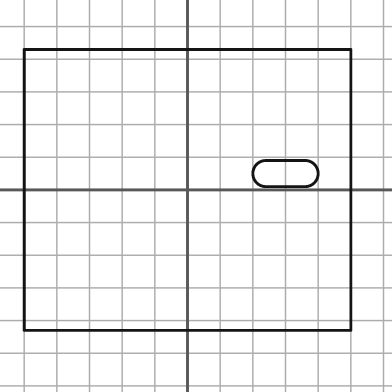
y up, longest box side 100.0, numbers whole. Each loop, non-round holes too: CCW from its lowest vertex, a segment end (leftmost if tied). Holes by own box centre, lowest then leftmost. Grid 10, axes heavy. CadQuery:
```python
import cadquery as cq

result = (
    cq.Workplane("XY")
    .moveTo(-50.0, -43.0)
    .lineTo(50.0, -43.0)
    .lineTo(50.0, 43.0)
    .lineTo(-50.0, 43.0)
    .close()
    .moveTo(24.0, 1.0)
    .lineTo(36.0, 1.0)
    .threePointArc((40.0, 5.0), (36.0, 9.0))
    .lineTo(24.0, 9.0)
    .threePointArc((20.0, 5.0), (24.0, 1.0))
    .close()
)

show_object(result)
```